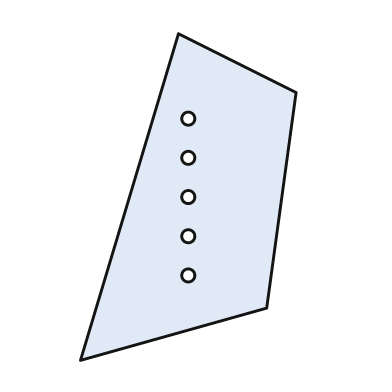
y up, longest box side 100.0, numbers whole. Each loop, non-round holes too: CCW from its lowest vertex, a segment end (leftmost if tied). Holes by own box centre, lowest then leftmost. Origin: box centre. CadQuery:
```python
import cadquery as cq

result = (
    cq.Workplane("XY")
    .moveTo(-33.0, -50.0)
    .lineTo(24.0, -34.0)
    .lineTo(33.0, 32.0)
    .lineTo(-3.0, 50.0)
    .close()
    .moveTo(0.0, -24.0)
    .circle(2.0)
    .moveTo(0.0, -12.0)
    .circle(2.0)
    .moveTo(0.0, 0.0)
    .circle(2.0)
    .moveTo(0.0, 12.0)
    .circle(2.0)
    .moveTo(0.0, 24.0)
    .circle(2.0)
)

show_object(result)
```